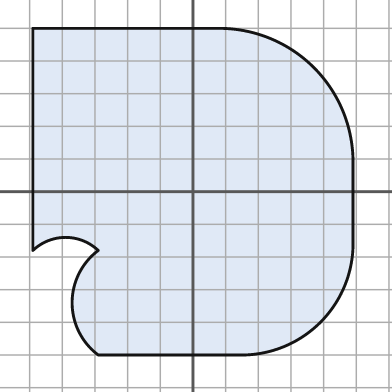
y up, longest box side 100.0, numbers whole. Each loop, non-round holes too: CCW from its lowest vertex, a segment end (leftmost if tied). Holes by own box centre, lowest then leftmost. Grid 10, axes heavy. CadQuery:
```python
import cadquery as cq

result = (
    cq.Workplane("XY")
    .moveTo(-29.0, -50.0)
    .lineTo(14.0, -50.0)
    .threePointArc((39.0, -40.0), (49.0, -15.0))
    .lineTo(49.0, 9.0)
    .threePointArc((37.0, 38.0), (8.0, 50.0))
    .lineTo(-49.0, 50.0)
    .lineTo(-49.0, -18.0)
    .threePointArc((-39.0, -14.0), (-29.0, -18.0))
    .threePointArc((-37.0, -34.0), (-29.0, -50.0))
    .close()
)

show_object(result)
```